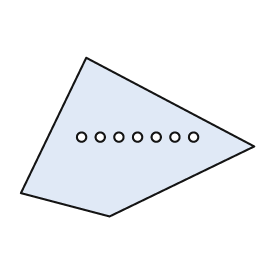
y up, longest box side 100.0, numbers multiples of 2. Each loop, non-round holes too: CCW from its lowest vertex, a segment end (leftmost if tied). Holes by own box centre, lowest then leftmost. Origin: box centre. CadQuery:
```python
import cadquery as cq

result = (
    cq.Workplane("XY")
    .moveTo(-12.0, -34.0)
    .lineTo(50.0, -4.0)
    .lineTo(-22.0, 34.0)
    .lineTo(-50.0, -24.0)
    .close()
    .moveTo(-24.0, 0.0)
    .circle(2.0)
    .moveTo(-16.0, 0.0)
    .circle(2.0)
    .moveTo(-8.0, 0.0)
    .circle(2.0)
    .moveTo(0.0, 0.0)
    .circle(2.0)
    .moveTo(8.0, 0.0)
    .circle(2.0)
    .moveTo(16.0, 0.0)
    .circle(2.0)
    .moveTo(24.0, 0.0)
    .circle(2.0)
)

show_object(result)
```